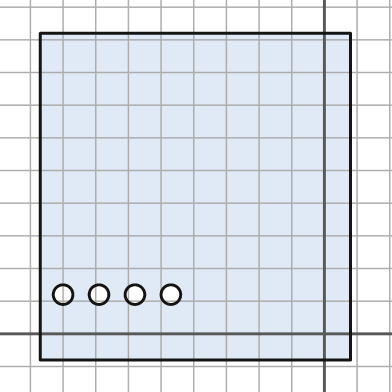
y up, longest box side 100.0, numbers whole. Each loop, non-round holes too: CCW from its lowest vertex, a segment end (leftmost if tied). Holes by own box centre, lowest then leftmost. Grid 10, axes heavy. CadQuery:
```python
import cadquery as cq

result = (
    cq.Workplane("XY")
    .moveTo(-87.0, -8.0)
    .lineTo(8.0, -8.0)
    .lineTo(8.0, 92.0)
    .lineTo(-87.0, 92.0)
    .close()
    .moveTo(-80.0, 12.0)
    .circle(3.0)
    .moveTo(-69.0, 12.0)
    .circle(3.0)
    .moveTo(-58.0, 12.0)
    .circle(3.0)
    .moveTo(-47.0, 12.0)
    .circle(3.0)
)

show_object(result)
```